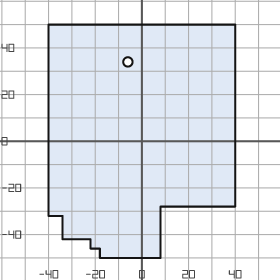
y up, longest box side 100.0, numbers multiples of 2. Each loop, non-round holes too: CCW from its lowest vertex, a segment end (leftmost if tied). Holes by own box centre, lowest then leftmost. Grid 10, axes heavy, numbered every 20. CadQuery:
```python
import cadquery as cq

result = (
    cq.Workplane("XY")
    .moveTo(-18.0, -50.0)
    .lineTo(8.0, -50.0)
    .lineTo(8.0, -28.0)
    .lineTo(40.0, -28.0)
    .lineTo(40.0, 50.0)
    .lineTo(-40.0, 50.0)
    .lineTo(-40.0, -32.0)
    .lineTo(-34.0, -32.0)
    .lineTo(-34.0, -42.0)
    .lineTo(-22.0, -42.0)
    .lineTo(-22.0, -46.0)
    .lineTo(-18.0, -46.0)
    .close()
    .moveTo(-6.0, 34.0)
    .circle(2.0)
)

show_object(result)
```